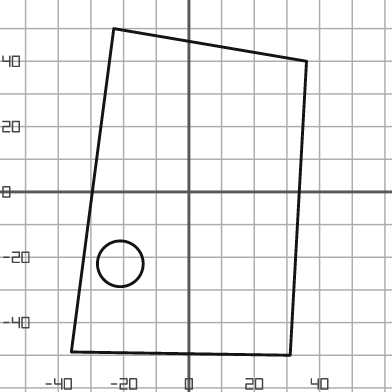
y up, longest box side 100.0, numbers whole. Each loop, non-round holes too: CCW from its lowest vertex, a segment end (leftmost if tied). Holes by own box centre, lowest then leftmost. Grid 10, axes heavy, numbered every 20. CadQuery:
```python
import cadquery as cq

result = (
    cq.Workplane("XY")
    .moveTo(31.0, -50.0)
    .lineTo(36.0, 40.0)
    .lineTo(-23.0, 50.0)
    .lineTo(-36.0, -49.0)
    .close()
    .moveTo(-21.0, -22.0)
    .circle(7.0)
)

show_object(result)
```